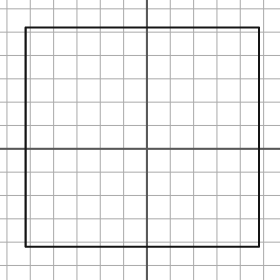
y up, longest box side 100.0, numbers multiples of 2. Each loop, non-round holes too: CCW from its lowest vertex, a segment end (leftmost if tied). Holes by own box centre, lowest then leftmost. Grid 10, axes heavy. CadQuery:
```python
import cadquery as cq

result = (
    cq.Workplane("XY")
    .moveTo(-52.0, -42.0)
    .lineTo(48.0, -42.0)
    .lineTo(48.0, 52.0)
    .lineTo(-52.0, 52.0)
    .close()
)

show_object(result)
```